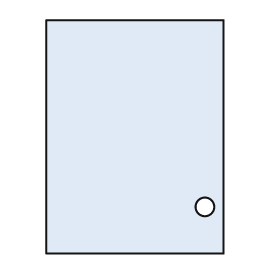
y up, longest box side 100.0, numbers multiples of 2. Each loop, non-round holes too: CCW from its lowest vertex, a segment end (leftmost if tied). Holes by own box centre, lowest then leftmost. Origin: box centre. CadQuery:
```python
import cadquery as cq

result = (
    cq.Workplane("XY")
    .moveTo(-38.0, -50.0)
    .lineTo(38.0, -50.0)
    .lineTo(38.0, 50.0)
    .lineTo(-38.0, 50.0)
    .close()
    .moveTo(30.0, -30.0)
    .circle(4.0)
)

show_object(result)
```